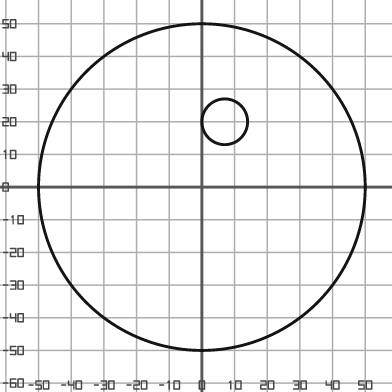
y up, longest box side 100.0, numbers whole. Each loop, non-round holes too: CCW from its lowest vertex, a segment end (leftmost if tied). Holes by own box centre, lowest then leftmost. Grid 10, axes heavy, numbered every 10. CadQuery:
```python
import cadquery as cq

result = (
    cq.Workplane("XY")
    .moveTo(0.0, 0.0)
    .circle(50.0)
    .moveTo(7.0, 20.0)
    .circle(7.0)
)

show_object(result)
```